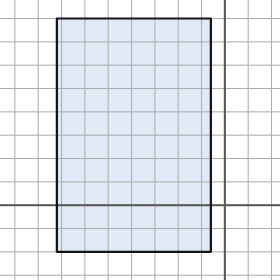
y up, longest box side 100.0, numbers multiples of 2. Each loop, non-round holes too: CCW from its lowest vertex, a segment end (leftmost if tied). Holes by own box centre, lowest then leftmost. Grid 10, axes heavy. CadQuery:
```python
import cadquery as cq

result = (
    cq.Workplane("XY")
    .moveTo(-72.0, -20.0)
    .lineTo(-6.0, -20.0)
    .lineTo(-6.0, 80.0)
    .lineTo(-72.0, 80.0)
    .close()
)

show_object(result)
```